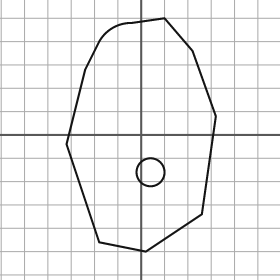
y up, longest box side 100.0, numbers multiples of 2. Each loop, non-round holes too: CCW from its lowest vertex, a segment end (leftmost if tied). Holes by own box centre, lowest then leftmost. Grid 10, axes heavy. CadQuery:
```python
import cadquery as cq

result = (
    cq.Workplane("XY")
    .moveTo(2.0, -50.0)
    .lineTo(26.0, -34.0)
    .lineTo(32.0, 8.0)
    .lineTo(22.0, 36.0)
    .lineTo(10.0, 50.0)
    .lineTo(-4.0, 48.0)
    .threePointArc((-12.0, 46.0), (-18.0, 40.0))
    .lineTo(-24.0, 28.0)
    .lineTo(-32.0, -4.0)
    .lineTo(-18.0, -46.0)
    .close()
    .moveTo(4.0, -16.0)
    .circle(6.0)
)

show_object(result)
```